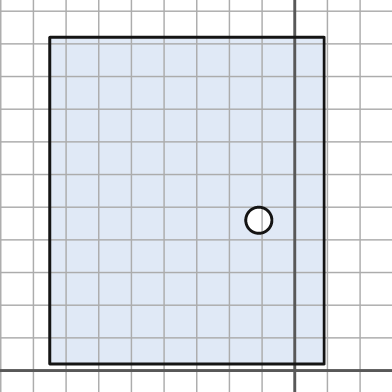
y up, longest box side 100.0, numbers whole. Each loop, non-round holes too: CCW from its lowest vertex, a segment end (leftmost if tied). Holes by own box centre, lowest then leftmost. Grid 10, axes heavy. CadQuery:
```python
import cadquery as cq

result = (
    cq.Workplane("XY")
    .moveTo(-75.0, 2.0)
    .lineTo(9.0, 2.0)
    .lineTo(9.0, 102.0)
    .lineTo(-75.0, 102.0)
    .close()
    .moveTo(-11.0, 46.0)
    .circle(4.0)
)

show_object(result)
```